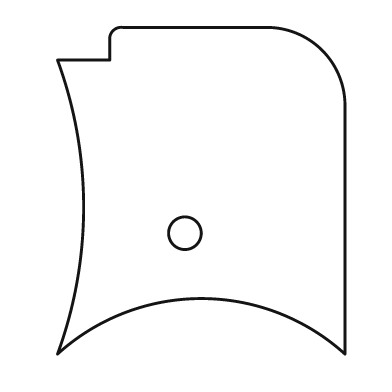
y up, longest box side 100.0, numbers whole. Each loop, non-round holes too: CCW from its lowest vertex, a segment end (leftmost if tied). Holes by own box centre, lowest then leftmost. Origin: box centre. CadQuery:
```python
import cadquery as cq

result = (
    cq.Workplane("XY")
    .moveTo(-44.0, -50.0)
    .threePointArc((0.0, -33.0), (44.0, -50.0))
    .lineTo(44.0, 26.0)
    .threePointArc((37.0, 43.0), (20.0, 50.0))
    .lineTo(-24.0, 50.0)
    .threePointArc((-27.0, 49.0), (-28.0, 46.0))
    .lineTo(-28.0, 40.0)
    .lineTo(-44.0, 40.0)
    .threePointArc((-36.0, -5.0), (-44.0, -50.0))
    .close()
    .moveTo(-5.0, -13.0)
    .circle(5.0)
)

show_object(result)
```